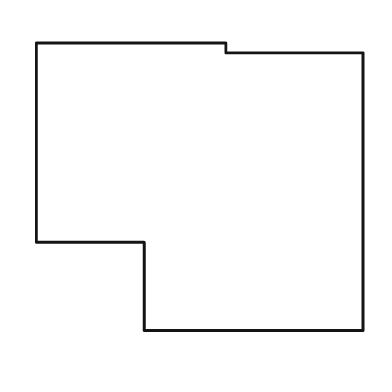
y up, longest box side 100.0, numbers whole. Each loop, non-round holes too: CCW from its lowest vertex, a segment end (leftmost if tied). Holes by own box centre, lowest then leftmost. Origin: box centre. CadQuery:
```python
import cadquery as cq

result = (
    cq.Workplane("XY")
    .moveTo(-17.0, -44.0)
    .lineTo(50.0, -44.0)
    .lineTo(50.0, 41.0)
    .lineTo(8.0, 41.0)
    .lineTo(8.0, 44.0)
    .lineTo(-50.0, 44.0)
    .lineTo(-50.0, -17.0)
    .lineTo(-17.0, -17.0)
    .close()
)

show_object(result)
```